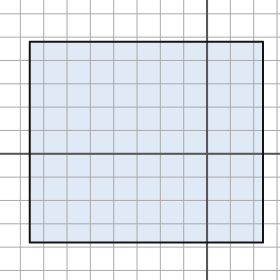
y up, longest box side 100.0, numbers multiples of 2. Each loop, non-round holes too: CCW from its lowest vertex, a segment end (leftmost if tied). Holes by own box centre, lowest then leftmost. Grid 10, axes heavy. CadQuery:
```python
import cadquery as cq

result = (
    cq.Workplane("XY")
    .moveTo(-76.0, -38.0)
    .lineTo(24.0, -38.0)
    .lineTo(24.0, 48.0)
    .lineTo(-76.0, 48.0)
    .close()
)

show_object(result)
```